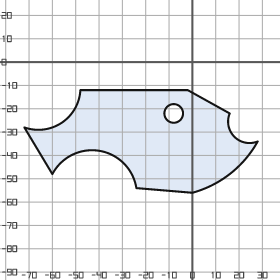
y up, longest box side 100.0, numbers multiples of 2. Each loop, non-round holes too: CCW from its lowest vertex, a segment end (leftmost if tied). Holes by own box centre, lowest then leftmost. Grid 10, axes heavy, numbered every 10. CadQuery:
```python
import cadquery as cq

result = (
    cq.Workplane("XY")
    .moveTo(0.0, -56.0)
    .threePointArc((16.0, -48.0), (28.0, -34.0))
    .threePointArc((18.0, -32.0), (16.0, -22.0))
    .lineTo(-2.0, -12.0)
    .lineTo(-48.0, -12.0)
    .threePointArc((-56.0, -26.0), (-72.0, -28.0))
    .lineTo(-60.0, -48.0)
    .threePointArc((-40.0, -38.0), (-24.0, -54.0))
    .close()
    .moveTo(-8.0, -22.0)
    .circle(4.0)
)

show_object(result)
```